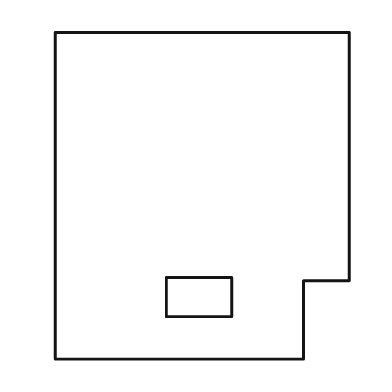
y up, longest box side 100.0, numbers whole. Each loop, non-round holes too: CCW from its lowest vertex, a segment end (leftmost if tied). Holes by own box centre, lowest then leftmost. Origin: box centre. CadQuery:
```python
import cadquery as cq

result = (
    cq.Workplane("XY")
    .moveTo(-45.0, -50.0)
    .lineTo(31.0, -50.0)
    .lineTo(31.0, -26.0)
    .lineTo(45.0, -26.0)
    .lineTo(45.0, 50.0)
    .lineTo(-45.0, 50.0)
    .close()
    .moveTo(-11.0, -37.0)
    .lineTo(9.0, -37.0)
    .lineTo(9.0, -25.0)
    .lineTo(-11.0, -25.0)
    .close()
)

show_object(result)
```